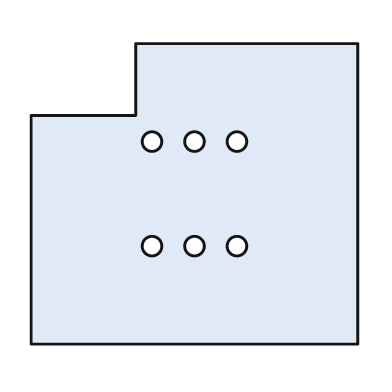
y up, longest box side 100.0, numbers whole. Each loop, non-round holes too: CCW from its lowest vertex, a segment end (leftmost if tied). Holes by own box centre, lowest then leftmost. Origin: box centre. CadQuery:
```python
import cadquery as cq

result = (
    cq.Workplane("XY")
    .moveTo(-50.0, -46.0)
    .lineTo(50.0, -46.0)
    .lineTo(50.0, 46.0)
    .lineTo(-18.0, 46.0)
    .lineTo(-18.0, 24.0)
    .lineTo(-50.0, 24.0)
    .close()
    .moveTo(-13.0, -16.0)
    .circle(3.0)
    .moveTo(0.0, -16.0)
    .circle(3.0)
    .moveTo(13.0, -16.0)
    .circle(3.0)
    .moveTo(-13.0, 16.0)
    .circle(3.0)
    .moveTo(0.0, 16.0)
    .circle(3.0)
    .moveTo(13.0, 16.0)
    .circle(3.0)
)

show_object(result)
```